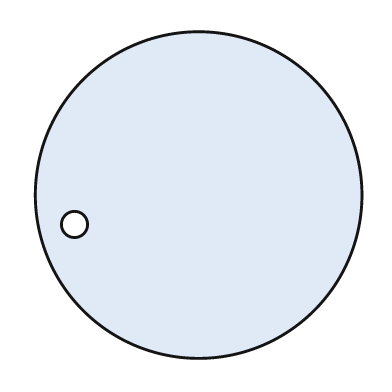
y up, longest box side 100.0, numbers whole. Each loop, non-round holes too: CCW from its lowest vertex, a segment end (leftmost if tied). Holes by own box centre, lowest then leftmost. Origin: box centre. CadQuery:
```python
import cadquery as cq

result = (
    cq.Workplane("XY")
    .moveTo(0.0, 0.0)
    .circle(50.0)
    .moveTo(-38.0, -9.0)
    .circle(4.0)
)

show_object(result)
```